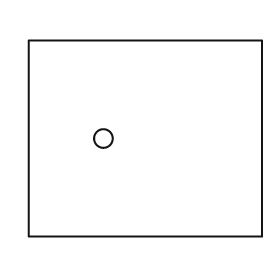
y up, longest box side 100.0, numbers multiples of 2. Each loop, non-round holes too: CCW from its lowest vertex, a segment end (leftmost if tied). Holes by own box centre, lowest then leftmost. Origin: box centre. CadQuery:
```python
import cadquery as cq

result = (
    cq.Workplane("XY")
    .moveTo(-50.0, -42.0)
    .lineTo(50.0, -42.0)
    .lineTo(50.0, 42.0)
    .lineTo(-50.0, 42.0)
    .close()
    .moveTo(-18.0, 0.0)
    .circle(4.0)
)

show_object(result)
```